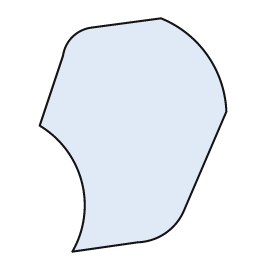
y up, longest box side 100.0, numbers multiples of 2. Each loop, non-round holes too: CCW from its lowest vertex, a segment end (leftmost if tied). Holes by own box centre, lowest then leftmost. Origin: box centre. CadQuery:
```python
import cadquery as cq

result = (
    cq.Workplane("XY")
    .moveTo(-26.0, -50.0)
    .lineTo(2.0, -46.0)
    .threePointArc((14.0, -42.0), (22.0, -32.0))
    .lineTo(40.0, 10.0)
    .threePointArc((32.0, 34.0), (12.0, 50.0))
    .lineTo(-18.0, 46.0)
    .threePointArc((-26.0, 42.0), (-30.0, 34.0))
    .lineTo(-40.0, 4.0)
    .threePointArc((-22.0, -20.0), (-26.0, -50.0))
    .close()
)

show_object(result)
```